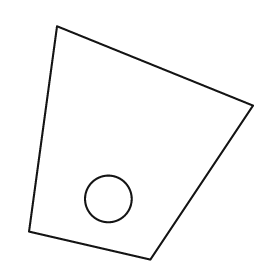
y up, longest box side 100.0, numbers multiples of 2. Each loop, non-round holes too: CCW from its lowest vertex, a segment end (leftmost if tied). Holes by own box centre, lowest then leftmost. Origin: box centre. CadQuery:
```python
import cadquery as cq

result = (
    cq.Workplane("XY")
    .moveTo(4.0, -50.0)
    .lineTo(48.0, 16.0)
    .lineTo(-36.0, 50.0)
    .lineTo(-48.0, -38.0)
    .close()
    .moveTo(-14.0, -24.0)
    .circle(10.0)
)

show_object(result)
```